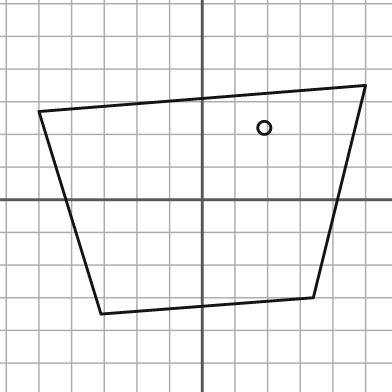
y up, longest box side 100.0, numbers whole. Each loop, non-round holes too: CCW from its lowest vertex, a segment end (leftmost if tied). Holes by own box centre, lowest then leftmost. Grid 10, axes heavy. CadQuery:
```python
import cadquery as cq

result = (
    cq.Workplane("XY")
    .moveTo(-31.0, -35.0)
    .lineTo(34.0, -30.0)
    .lineTo(50.0, 35.0)
    .lineTo(-50.0, 27.0)
    .close()
    .moveTo(19.0, 22.0)
    .circle(2.0)
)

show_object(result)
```